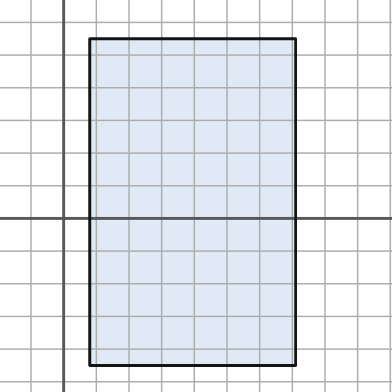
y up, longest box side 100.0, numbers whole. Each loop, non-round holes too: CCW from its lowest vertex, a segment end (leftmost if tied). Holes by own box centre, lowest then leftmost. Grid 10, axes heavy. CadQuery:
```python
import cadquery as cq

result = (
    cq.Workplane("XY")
    .moveTo(8.0, -45.0)
    .lineTo(71.0, -45.0)
    .lineTo(71.0, 55.0)
    .lineTo(8.0, 55.0)
    .close()
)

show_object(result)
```